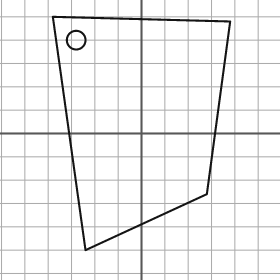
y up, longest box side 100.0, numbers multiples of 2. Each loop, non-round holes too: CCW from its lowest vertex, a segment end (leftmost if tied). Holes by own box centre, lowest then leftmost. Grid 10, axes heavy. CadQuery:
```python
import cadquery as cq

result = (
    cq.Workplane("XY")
    .moveTo(-24.0, -50.0)
    .lineTo(28.0, -26.0)
    .lineTo(38.0, 48.0)
    .lineTo(-38.0, 50.0)
    .close()
    .moveTo(-28.0, 40.0)
    .circle(4.0)
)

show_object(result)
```